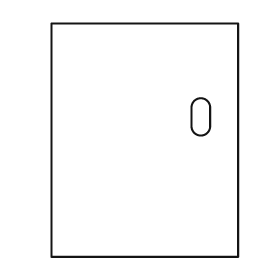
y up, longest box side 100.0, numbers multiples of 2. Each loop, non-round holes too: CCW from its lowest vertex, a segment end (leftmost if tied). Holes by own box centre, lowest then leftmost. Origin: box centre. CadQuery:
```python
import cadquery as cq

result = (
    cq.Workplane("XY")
    .moveTo(-40.0, -50.0)
    .lineTo(40.0, -50.0)
    .lineTo(40.0, 50.0)
    .lineTo(-40.0, 50.0)
    .close()
    .moveTo(20.0, 6.0)
    .threePointArc((24.0, 2.0), (28.0, 6.0))
    .lineTo(28.0, 14.0)
    .threePointArc((24.0, 18.0), (20.0, 14.0))
    .close()
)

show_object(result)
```